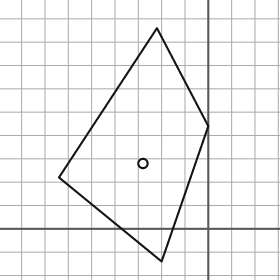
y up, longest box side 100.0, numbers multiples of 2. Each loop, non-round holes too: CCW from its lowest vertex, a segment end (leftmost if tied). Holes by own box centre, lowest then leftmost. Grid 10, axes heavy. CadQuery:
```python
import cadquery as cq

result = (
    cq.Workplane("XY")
    .moveTo(-20.0, -14.0)
    .lineTo(0.0, 44.0)
    .lineTo(-22.0, 86.0)
    .lineTo(-64.0, 22.0)
    .close()
    .moveTo(-28.0, 28.0)
    .circle(2.0)
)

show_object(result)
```